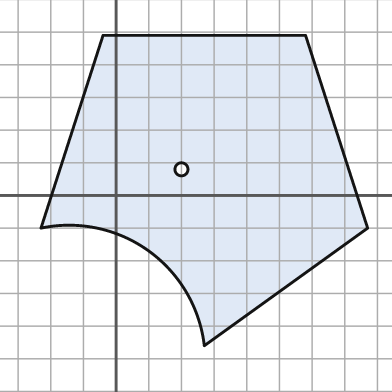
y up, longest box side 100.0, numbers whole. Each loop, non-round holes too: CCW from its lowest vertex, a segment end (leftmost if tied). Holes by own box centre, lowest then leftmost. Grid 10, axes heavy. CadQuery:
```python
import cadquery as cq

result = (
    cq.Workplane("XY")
    .moveTo(27.0, -46.0)
    .lineTo(77.0, -10.0)
    .lineTo(58.0, 49.0)
    .lineTo(-4.0, 49.0)
    .lineTo(-23.0, -10.0)
    .threePointArc((10.0, -17.0), (27.0, -46.0))
    .close()
    .moveTo(20.0, 8.0)
    .circle(2.0)
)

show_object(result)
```